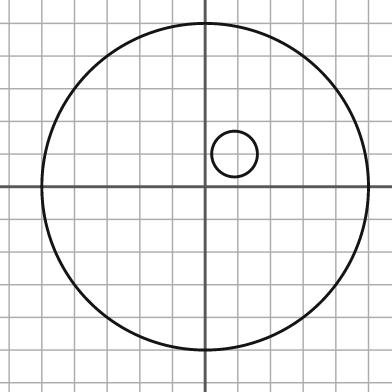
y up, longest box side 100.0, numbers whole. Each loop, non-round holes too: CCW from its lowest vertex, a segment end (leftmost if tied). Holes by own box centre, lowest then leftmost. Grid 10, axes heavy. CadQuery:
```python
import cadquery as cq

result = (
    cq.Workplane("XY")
    .moveTo(0.0, 0.0)
    .circle(50.0)
    .moveTo(9.0, 10.0)
    .circle(7.0)
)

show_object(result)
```